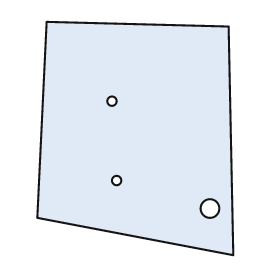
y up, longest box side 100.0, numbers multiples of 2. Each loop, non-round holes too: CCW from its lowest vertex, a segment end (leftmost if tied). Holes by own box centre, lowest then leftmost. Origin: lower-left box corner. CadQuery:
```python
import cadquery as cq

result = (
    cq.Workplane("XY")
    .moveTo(84.0, 0.0)
    .lineTo(82.0, 98.0)
    .lineTo(4.0, 100.0)
    .lineTo(0.0, 16.0)
    .close()
    .moveTo(74.0, 20.0)
    .circle(4.0)
    .moveTo(34.0, 32.0)
    .circle(2.0)
    .moveTo(32.0, 66.0)
    .circle(2.0)
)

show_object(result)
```